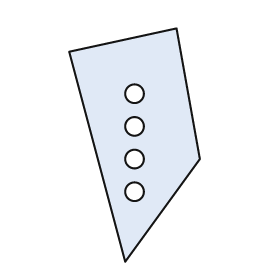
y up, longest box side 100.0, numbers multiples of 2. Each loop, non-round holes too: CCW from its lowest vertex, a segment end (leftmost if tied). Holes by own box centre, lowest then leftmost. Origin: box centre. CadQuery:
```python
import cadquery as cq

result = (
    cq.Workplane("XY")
    .moveTo(-4.0, -50.0)
    .lineTo(28.0, -6.0)
    .lineTo(18.0, 50.0)
    .lineTo(-28.0, 40.0)
    .close()
    .moveTo(0.0, -20.0)
    .circle(4.0)
    .moveTo(0.0, -6.0)
    .circle(4.0)
    .moveTo(0.0, 8.0)
    .circle(4.0)
    .moveTo(0.0, 22.0)
    .circle(4.0)
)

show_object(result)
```